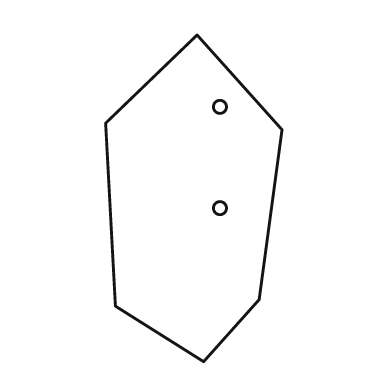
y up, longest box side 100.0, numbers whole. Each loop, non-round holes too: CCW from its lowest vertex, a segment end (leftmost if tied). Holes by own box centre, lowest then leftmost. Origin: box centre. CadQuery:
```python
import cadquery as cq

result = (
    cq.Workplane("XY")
    .moveTo(3.0, -50.0)
    .lineTo(20.0, -31.0)
    .lineTo(27.0, 21.0)
    .lineTo(1.0, 50.0)
    .lineTo(-27.0, 23.0)
    .lineTo(-24.0, -33.0)
    .close()
    .moveTo(8.0, -3.0)
    .circle(2.0)
    .moveTo(8.0, 28.0)
    .circle(2.0)
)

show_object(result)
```